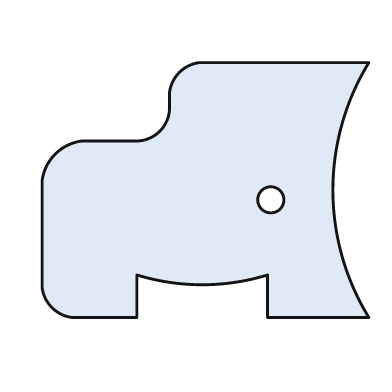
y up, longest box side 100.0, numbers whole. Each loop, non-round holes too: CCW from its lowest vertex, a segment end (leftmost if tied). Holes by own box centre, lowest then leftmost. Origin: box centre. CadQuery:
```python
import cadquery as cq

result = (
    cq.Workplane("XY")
    .moveTo(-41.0, -39.0)
    .lineTo(-21.0, -39.0)
    .lineTo(-21.0, -26.0)
    .threePointArc((-1.0, -29.0), (19.0, -26.0))
    .lineTo(19.0, -39.0)
    .lineTo(50.0, -39.0)
    .threePointArc((39.0, 0.0), (50.0, 39.0))
    .lineTo(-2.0, 39.0)
    .threePointArc((-8.0, 36.0), (-11.0, 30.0))
    .lineTo(-11.0, 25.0)
    .threePointArc((-14.0, 18.0), (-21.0, 15.0))
    .lineTo(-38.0, 15.0)
    .threePointArc((-46.0, 11.0), (-50.0, 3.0))
    .lineTo(-50.0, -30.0)
    .threePointArc((-47.0, -36.0), (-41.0, -39.0))
    .close()
    .moveTo(20.0, -3.0)
    .circle(4.0)
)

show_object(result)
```